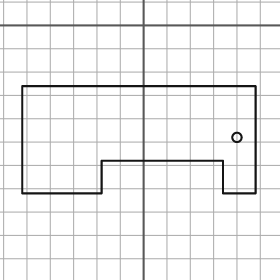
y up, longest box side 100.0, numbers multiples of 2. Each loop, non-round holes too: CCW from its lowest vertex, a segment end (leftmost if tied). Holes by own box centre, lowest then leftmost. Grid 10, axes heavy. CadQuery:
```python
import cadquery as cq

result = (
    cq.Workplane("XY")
    .moveTo(-52.0, -72.0)
    .lineTo(-18.0, -72.0)
    .lineTo(-18.0, -58.0)
    .lineTo(34.0, -58.0)
    .lineTo(34.0, -72.0)
    .lineTo(48.0, -72.0)
    .lineTo(48.0, -26.0)
    .lineTo(-52.0, -26.0)
    .close()
    .moveTo(40.0, -48.0)
    .circle(2.0)
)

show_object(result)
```